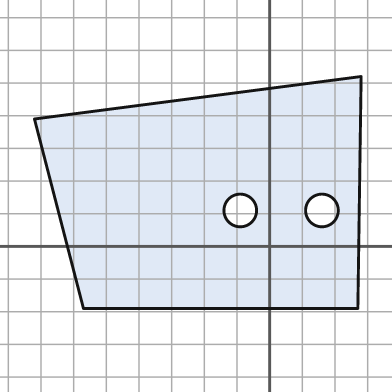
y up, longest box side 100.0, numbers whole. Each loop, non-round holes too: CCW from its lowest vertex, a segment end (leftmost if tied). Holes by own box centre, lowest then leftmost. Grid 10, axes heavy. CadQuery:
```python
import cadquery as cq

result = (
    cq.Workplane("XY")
    .moveTo(-57.0, -19.0)
    .lineTo(27.0, -19.0)
    .lineTo(28.0, 52.0)
    .lineTo(-72.0, 39.0)
    .close()
    .moveTo(-9.0, 11.0)
    .circle(5.0)
    .moveTo(16.0, 11.0)
    .circle(5.0)
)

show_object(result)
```